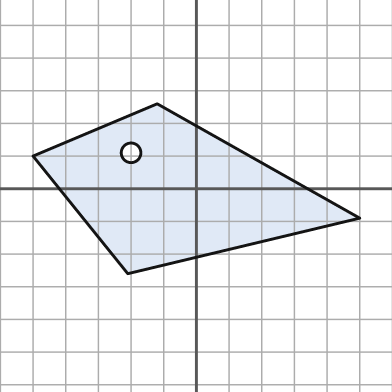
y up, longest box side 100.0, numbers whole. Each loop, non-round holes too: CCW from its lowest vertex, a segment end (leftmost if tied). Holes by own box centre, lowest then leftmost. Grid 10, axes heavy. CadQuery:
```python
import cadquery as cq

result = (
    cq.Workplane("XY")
    .moveTo(-21.0, -26.0)
    .lineTo(50.0, -9.0)
    .lineTo(-12.0, 26.0)
    .lineTo(-50.0, 10.0)
    .close()
    .moveTo(-20.0, 11.0)
    .circle(3.0)
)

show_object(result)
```